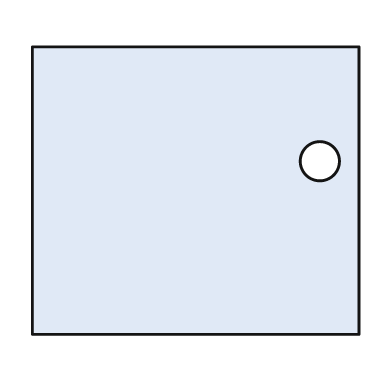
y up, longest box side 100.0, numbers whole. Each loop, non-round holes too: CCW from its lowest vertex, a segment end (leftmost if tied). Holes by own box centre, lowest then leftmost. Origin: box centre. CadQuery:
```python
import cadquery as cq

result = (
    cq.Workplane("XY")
    .moveTo(-50.0, -44.0)
    .lineTo(50.0, -44.0)
    .lineTo(50.0, 44.0)
    .lineTo(-50.0, 44.0)
    .close()
    .moveTo(38.0, 9.0)
    .circle(6.0)
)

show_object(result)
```